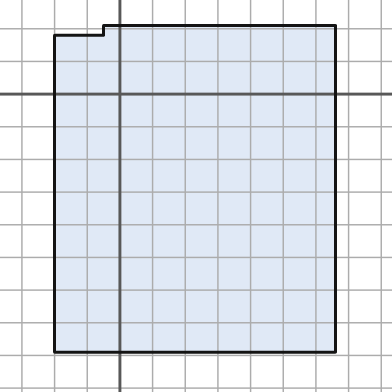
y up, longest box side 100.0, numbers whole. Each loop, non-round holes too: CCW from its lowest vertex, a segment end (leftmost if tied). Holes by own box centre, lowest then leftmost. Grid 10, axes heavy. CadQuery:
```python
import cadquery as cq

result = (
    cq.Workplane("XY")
    .moveTo(-20.0, -79.0)
    .lineTo(66.0, -79.0)
    .lineTo(66.0, 21.0)
    .lineTo(-5.0, 21.0)
    .lineTo(-5.0, 18.0)
    .lineTo(-20.0, 18.0)
    .close()
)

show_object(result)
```